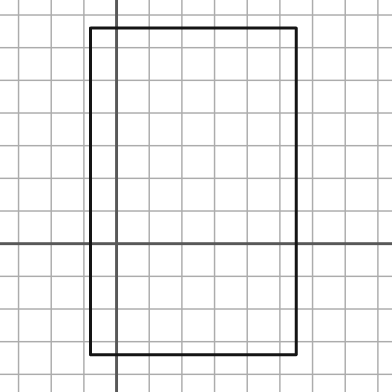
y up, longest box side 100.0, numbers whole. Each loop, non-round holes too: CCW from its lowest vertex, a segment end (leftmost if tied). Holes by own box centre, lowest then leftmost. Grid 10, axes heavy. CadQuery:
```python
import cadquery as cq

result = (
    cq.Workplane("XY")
    .moveTo(-8.0, -34.0)
    .lineTo(55.0, -34.0)
    .lineTo(55.0, 66.0)
    .lineTo(-8.0, 66.0)
    .close()
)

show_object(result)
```